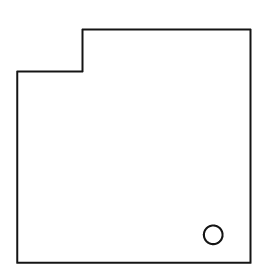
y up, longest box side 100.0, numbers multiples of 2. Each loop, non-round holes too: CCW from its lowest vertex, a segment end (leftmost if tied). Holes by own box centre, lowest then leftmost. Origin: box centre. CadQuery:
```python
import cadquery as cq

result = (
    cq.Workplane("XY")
    .moveTo(-50.0, -50.0)
    .lineTo(50.0, -50.0)
    .lineTo(50.0, 50.0)
    .lineTo(-22.0, 50.0)
    .lineTo(-22.0, 32.0)
    .lineTo(-50.0, 32.0)
    .close()
    .moveTo(34.0, -38.0)
    .circle(4.0)
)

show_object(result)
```